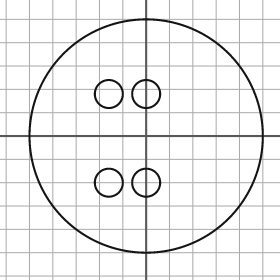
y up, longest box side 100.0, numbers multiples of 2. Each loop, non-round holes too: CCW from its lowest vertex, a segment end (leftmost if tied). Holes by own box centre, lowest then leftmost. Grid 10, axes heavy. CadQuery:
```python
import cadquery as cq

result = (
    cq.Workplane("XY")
    .moveTo(0.0, 0.0)
    .circle(50.0)
    .moveTo(-16.0, -20.0)
    .circle(6.0)
    .moveTo(0.0, -20.0)
    .circle(6.0)
    .moveTo(-16.0, 18.0)
    .circle(6.0)
    .moveTo(0.0, 18.0)
    .circle(6.0)
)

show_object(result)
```